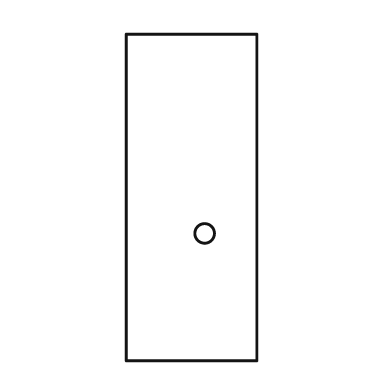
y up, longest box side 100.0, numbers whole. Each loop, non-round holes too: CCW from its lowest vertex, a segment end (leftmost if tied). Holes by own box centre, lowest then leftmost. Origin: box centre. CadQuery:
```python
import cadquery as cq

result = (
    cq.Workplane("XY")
    .moveTo(-20.0, -50.0)
    .lineTo(20.0, -50.0)
    .lineTo(20.0, 50.0)
    .lineTo(-20.0, 50.0)
    .close()
    .moveTo(4.0, -11.0)
    .circle(3.0)
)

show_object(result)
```